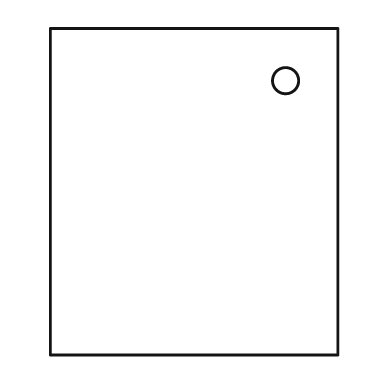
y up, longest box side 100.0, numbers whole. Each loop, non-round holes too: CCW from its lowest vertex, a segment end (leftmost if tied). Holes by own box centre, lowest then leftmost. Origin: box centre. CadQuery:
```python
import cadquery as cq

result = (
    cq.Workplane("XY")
    .moveTo(-44.0, -50.0)
    .lineTo(44.0, -50.0)
    .lineTo(44.0, 50.0)
    .lineTo(-44.0, 50.0)
    .close()
    .moveTo(28.0, 34.0)
    .circle(4.0)
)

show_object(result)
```